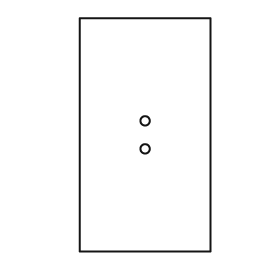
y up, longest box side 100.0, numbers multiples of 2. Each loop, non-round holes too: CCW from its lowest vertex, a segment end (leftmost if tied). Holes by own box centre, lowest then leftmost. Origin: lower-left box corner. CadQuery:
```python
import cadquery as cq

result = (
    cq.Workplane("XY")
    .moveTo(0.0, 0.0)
    .lineTo(56.0, 0.0)
    .lineTo(56.0, 100.0)
    .lineTo(0.0, 100.0)
    .close()
    .moveTo(28.0, 44.0)
    .circle(2.0)
    .moveTo(28.0, 56.0)
    .circle(2.0)
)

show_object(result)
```